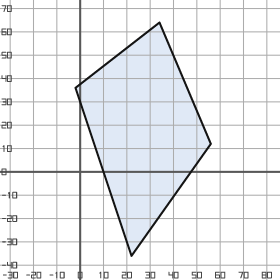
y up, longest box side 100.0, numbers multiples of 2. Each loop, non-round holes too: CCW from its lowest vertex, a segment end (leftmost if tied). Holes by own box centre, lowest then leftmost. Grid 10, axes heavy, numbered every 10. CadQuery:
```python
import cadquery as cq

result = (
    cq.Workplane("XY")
    .moveTo(22.0, -36.0)
    .lineTo(56.0, 12.0)
    .lineTo(34.0, 64.0)
    .lineTo(-2.0, 36.0)
    .close()
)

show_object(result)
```